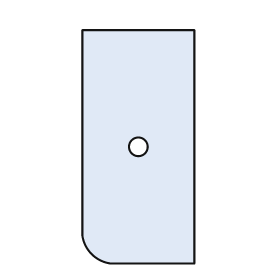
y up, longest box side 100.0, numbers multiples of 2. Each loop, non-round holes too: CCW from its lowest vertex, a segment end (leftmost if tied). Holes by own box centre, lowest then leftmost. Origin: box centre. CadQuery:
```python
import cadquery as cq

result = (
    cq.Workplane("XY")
    .moveTo(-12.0, -50.0)
    .lineTo(24.0, -50.0)
    .lineTo(24.0, 50.0)
    .lineTo(-24.0, 50.0)
    .lineTo(-24.0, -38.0)
    .threePointArc((-20.0, -46.0), (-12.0, -50.0))
    .close()
    .moveTo(0.0, 0.0)
    .circle(4.0)
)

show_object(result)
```